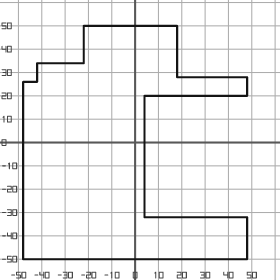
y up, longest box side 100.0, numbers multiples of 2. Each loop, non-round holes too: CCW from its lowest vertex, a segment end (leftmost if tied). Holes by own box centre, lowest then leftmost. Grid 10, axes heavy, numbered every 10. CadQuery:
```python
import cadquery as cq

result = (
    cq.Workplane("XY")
    .moveTo(-48.0, -50.0)
    .lineTo(48.0, -50.0)
    .lineTo(48.0, -32.0)
    .lineTo(4.0, -32.0)
    .lineTo(4.0, 20.0)
    .lineTo(48.0, 20.0)
    .lineTo(48.0, 28.0)
    .lineTo(18.0, 28.0)
    .lineTo(18.0, 50.0)
    .lineTo(-22.0, 50.0)
    .lineTo(-22.0, 34.0)
    .lineTo(-42.0, 34.0)
    .lineTo(-42.0, 26.0)
    .lineTo(-48.0, 26.0)
    .close()
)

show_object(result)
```